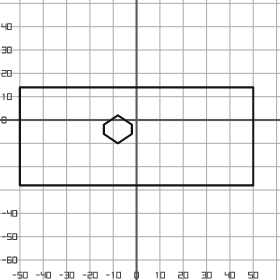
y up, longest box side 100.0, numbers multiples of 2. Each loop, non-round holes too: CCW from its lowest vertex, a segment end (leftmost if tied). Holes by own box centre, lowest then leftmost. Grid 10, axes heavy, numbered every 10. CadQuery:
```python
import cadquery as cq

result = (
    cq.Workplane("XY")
    .moveTo(-50.0, -28.0)
    .lineTo(50.0, -28.0)
    .lineTo(50.0, 14.0)
    .lineTo(-50.0, 14.0)
    .close()
    .moveTo(-8.0, -10.0)
    .lineTo(-2.0, -6.0)
    .lineTo(-2.0, -2.0)
    .lineTo(-8.0, 2.0)
    .lineTo(-14.0, -2.0)
    .lineTo(-14.0, -6.0)
    .close()
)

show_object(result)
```